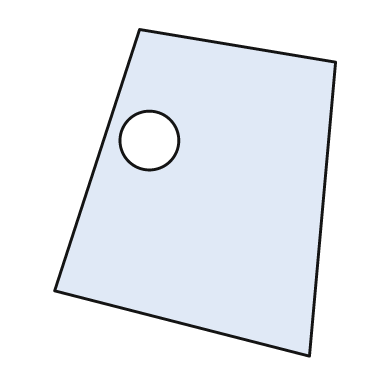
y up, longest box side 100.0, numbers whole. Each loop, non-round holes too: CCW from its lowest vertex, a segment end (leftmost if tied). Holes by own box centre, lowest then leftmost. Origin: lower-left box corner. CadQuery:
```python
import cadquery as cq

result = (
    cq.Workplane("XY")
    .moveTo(78.0, 0.0)
    .lineTo(86.0, 90.0)
    .lineTo(26.0, 100.0)
    .lineTo(0.0, 20.0)
    .close()
    .moveTo(29.0, 66.0)
    .circle(9.0)
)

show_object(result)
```